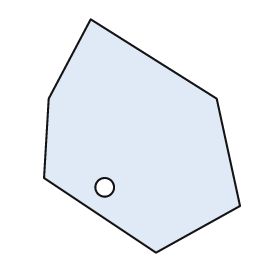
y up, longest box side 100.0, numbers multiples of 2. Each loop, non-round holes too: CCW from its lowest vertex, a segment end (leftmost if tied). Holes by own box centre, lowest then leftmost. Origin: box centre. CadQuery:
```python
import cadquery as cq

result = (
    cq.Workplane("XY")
    .moveTo(6.0, -50.0)
    .lineTo(42.0, -30.0)
    .lineTo(32.0, 16.0)
    .lineTo(-22.0, 50.0)
    .lineTo(-40.0, 16.0)
    .lineTo(-42.0, -18.0)
    .close()
    .moveTo(-16.0, -22.0)
    .circle(4.0)
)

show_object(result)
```